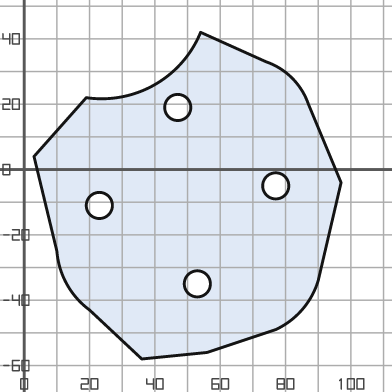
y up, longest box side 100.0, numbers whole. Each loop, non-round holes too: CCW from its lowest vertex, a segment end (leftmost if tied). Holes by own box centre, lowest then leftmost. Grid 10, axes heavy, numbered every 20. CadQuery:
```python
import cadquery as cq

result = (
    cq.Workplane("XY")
    .moveTo(36.0, -58.0)
    .lineTo(56.0, -56.0)
    .lineTo(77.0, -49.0)
    .threePointArc((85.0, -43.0), (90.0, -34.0))
    .lineTo(97.0, -4.0)
    .lineTo(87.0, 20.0)
    .threePointArc((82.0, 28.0), (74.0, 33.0))
    .lineTo(54.0, 42.0)
    .threePointArc((40.0, 26.0), (19.0, 22.0))
    .lineTo(3.0, 4.0)
    .lineTo(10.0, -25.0)
    .threePointArc((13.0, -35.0), (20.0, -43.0))
    .close()
    .moveTo(53.0, -35.0)
    .circle(4.0)
    .moveTo(23.0, -11.0)
    .circle(4.0)
    .moveTo(77.0, -5.0)
    .circle(4.0)
    .moveTo(47.0, 19.0)
    .circle(4.0)
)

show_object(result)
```